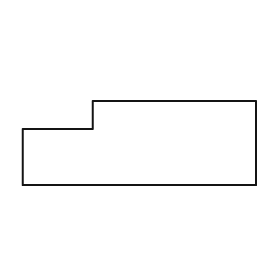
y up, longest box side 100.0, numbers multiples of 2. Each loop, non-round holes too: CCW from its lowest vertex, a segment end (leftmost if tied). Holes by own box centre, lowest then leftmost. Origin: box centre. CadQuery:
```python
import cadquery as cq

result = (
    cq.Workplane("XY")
    .moveTo(-50.0, -18.0)
    .lineTo(50.0, -18.0)
    .lineTo(50.0, 18.0)
    .lineTo(-20.0, 18.0)
    .lineTo(-20.0, 6.0)
    .lineTo(-50.0, 6.0)
    .close()
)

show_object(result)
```